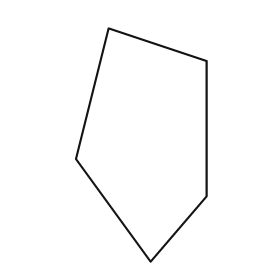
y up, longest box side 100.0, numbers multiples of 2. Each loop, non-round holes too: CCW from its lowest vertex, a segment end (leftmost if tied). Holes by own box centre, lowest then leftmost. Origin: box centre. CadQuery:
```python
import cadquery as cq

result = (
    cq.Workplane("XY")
    .moveTo(4.0, -50.0)
    .lineTo(28.0, -22.0)
    .lineTo(28.0, 36.0)
    .lineTo(-14.0, 50.0)
    .lineTo(-28.0, -6.0)
    .close()
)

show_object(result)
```